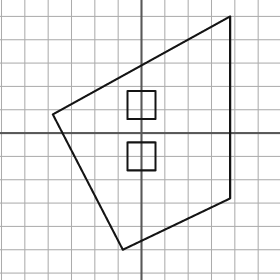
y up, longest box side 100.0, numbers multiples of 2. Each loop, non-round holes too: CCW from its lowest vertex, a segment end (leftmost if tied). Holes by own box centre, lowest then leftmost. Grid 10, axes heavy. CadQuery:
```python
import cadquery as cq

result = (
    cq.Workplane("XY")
    .moveTo(-8.0, -50.0)
    .lineTo(38.0, -28.0)
    .lineTo(38.0, 50.0)
    .lineTo(-38.0, 8.0)
    .close()
    .moveTo(-6.0, -16.0)
    .lineTo(6.0, -16.0)
    .lineTo(6.0, -4.0)
    .lineTo(-6.0, -4.0)
    .close()
    .moveTo(-6.0, 6.0)
    .lineTo(6.0, 6.0)
    .lineTo(6.0, 18.0)
    .lineTo(-6.0, 18.0)
    .close()
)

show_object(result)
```